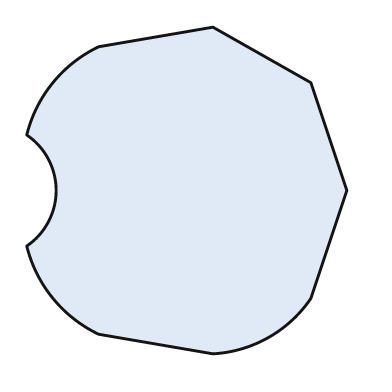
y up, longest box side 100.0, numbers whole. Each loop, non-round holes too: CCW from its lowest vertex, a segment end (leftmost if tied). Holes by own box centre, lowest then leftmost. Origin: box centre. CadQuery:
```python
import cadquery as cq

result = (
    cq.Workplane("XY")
    .moveTo(8.0, -50.0)
    .threePointArc((25.0, -45.0), (38.0, -33.0))
    .lineTo(49.0, 0.0)
    .lineTo(38.0, 33.0)
    .lineTo(8.0, 50.0)
    .lineTo(-27.0, 44.0)
    .threePointArc((-41.0, 33.0), (-49.0, 17.0))
    .threePointArc((-40.0, 0.0), (-49.0, -17.0))
    .threePointArc((-41.0, -33.0), (-27.0, -44.0))
    .close()
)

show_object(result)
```